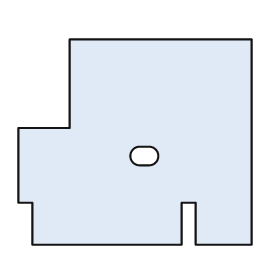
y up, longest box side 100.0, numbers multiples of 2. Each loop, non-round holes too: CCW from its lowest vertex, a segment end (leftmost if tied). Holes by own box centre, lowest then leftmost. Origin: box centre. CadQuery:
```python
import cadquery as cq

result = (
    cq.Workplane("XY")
    .moveTo(-44.0, -44.0)
    .lineTo(20.0, -44.0)
    .lineTo(20.0, -26.0)
    .lineTo(26.0, -26.0)
    .lineTo(26.0, -44.0)
    .lineTo(50.0, -44.0)
    .lineTo(50.0, 44.0)
    .lineTo(-28.0, 44.0)
    .lineTo(-28.0, 6.0)
    .lineTo(-50.0, 6.0)
    .lineTo(-50.0, -26.0)
    .lineTo(-44.0, -26.0)
    .close()
    .moveTo(2.0, -10.0)
    .lineTo(6.0, -10.0)
    .threePointArc((10.0, -6.0), (6.0, -2.0))
    .lineTo(2.0, -2.0)
    .threePointArc((-2.0, -6.0), (2.0, -10.0))
    .close()
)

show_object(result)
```